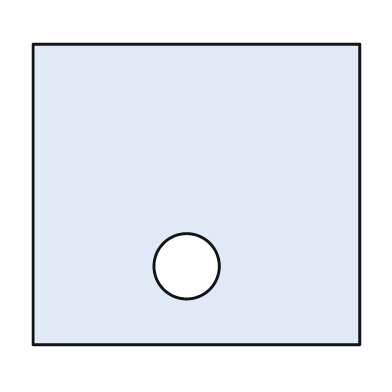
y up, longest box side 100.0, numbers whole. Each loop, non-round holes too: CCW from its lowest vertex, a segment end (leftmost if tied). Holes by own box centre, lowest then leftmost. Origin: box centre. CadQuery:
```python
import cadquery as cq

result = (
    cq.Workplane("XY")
    .moveTo(-50.0, -46.0)
    .lineTo(50.0, -46.0)
    .lineTo(50.0, 46.0)
    .lineTo(-50.0, 46.0)
    .close()
    .moveTo(-3.0, -22.0)
    .circle(10.0)
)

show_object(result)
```